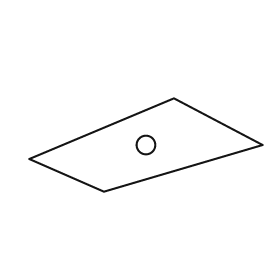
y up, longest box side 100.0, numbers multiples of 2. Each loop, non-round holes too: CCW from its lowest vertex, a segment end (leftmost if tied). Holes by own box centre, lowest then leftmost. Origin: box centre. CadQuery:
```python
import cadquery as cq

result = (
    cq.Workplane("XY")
    .moveTo(-18.0, -20.0)
    .lineTo(50.0, 0.0)
    .lineTo(12.0, 20.0)
    .lineTo(-50.0, -6.0)
    .close()
    .moveTo(0.0, 0.0)
    .circle(4.0)
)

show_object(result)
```